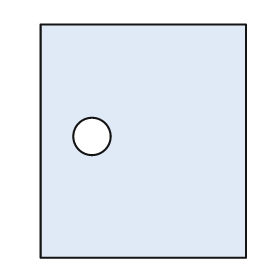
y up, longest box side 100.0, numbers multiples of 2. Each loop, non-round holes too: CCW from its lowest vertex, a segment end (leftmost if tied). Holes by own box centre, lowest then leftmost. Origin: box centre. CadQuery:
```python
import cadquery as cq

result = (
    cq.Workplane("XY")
    .moveTo(-44.0, -50.0)
    .lineTo(44.0, -50.0)
    .lineTo(44.0, 50.0)
    .lineTo(-44.0, 50.0)
    .close()
    .moveTo(-22.0, 2.0)
    .circle(8.0)
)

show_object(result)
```